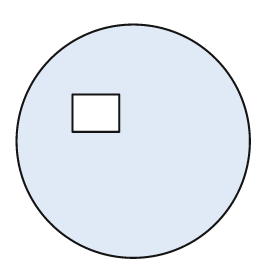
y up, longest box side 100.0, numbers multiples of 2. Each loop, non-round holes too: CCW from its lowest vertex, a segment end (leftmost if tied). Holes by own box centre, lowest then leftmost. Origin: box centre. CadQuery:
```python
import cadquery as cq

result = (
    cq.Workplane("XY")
    .moveTo(0.0, 0.0)
    .circle(50.0)
    .moveTo(-26.0, 4.0)
    .lineTo(-6.0, 4.0)
    .lineTo(-6.0, 20.0)
    .lineTo(-26.0, 20.0)
    .close()
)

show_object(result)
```